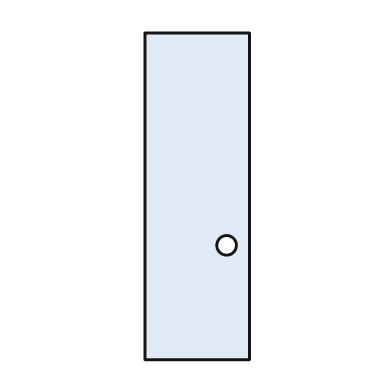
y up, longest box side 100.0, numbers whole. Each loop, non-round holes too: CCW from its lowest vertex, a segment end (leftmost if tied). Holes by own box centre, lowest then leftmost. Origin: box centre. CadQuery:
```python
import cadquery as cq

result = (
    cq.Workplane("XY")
    .moveTo(-16.0, -50.0)
    .lineTo(16.0, -50.0)
    .lineTo(16.0, 50.0)
    .lineTo(-16.0, 50.0)
    .close()
    .moveTo(9.0, -15.0)
    .circle(3.0)
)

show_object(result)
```